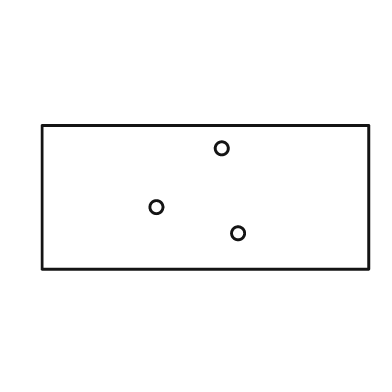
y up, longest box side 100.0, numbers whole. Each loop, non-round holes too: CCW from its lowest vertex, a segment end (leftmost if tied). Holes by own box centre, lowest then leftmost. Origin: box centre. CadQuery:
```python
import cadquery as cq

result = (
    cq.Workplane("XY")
    .moveTo(-50.0, -22.0)
    .lineTo(50.0, -22.0)
    .lineTo(50.0, 22.0)
    .lineTo(-50.0, 22.0)
    .close()
    .moveTo(10.0, -11.0)
    .circle(2.0)
    .moveTo(-15.0, -3.0)
    .circle(2.0)
    .moveTo(5.0, 15.0)
    .circle(2.0)
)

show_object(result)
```